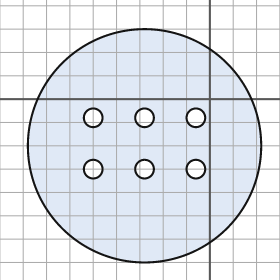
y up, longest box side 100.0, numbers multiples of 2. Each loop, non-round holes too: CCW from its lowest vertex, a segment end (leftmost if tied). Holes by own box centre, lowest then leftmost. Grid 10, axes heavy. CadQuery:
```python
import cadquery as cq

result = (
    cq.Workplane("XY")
    .moveTo(-28.0, -20.0)
    .circle(50.0)
    .moveTo(-50.0, -30.0)
    .circle(4.0)
    .moveTo(-28.0, -30.0)
    .circle(4.0)
    .moveTo(-6.0, -30.0)
    .circle(4.0)
    .moveTo(-50.0, -8.0)
    .circle(4.0)
    .moveTo(-28.0, -8.0)
    .circle(4.0)
    .moveTo(-6.0, -8.0)
    .circle(4.0)
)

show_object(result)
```